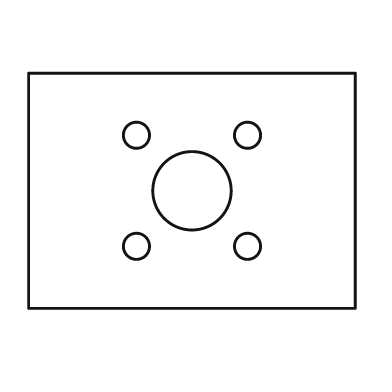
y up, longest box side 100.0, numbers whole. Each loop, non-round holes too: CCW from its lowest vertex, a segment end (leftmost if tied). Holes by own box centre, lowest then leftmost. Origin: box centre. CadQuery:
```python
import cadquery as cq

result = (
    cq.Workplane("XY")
    .moveTo(-50.0, -36.0)
    .lineTo(50.0, -36.0)
    .lineTo(50.0, 36.0)
    .lineTo(-50.0, 36.0)
    .close()
    .moveTo(-17.0, -17.0)
    .circle(4.0)
    .moveTo(17.0, -17.0)
    .circle(4.0)
    .moveTo(0.0, 0.0)
    .circle(12.0)
    .moveTo(-17.0, 17.0)
    .circle(4.0)
    .moveTo(17.0, 17.0)
    .circle(4.0)
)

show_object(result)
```